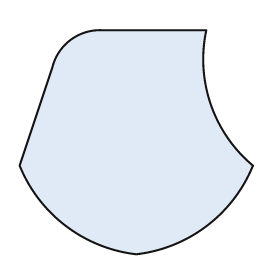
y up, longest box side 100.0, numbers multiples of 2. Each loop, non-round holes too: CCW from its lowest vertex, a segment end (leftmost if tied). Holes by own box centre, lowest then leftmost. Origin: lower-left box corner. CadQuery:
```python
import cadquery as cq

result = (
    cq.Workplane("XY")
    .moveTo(50.0, 0.0)
    .threePointArc((80.0, 12.0), (100.0, 38.0))
    .threePointArc((82.0, 64.0), (80.0, 96.0))
    .lineTo(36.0, 96.0)
    .threePointArc((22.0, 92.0), (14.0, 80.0))
    .lineTo(0.0, 38.0)
    .threePointArc((20.0, 12.0), (50.0, 0.0))
    .close()
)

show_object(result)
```